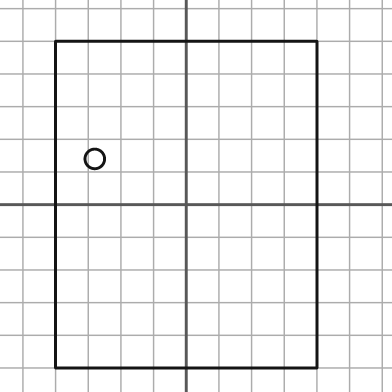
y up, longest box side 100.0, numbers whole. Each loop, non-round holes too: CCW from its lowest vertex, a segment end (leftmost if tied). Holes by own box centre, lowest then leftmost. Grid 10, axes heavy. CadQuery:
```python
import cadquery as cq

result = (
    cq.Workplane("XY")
    .moveTo(-40.0, -50.0)
    .lineTo(40.0, -50.0)
    .lineTo(40.0, 50.0)
    .lineTo(-40.0, 50.0)
    .close()
    .moveTo(-28.0, 14.0)
    .circle(3.0)
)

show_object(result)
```